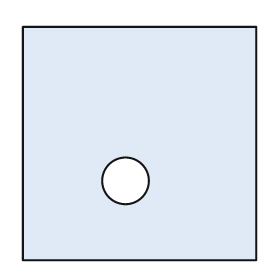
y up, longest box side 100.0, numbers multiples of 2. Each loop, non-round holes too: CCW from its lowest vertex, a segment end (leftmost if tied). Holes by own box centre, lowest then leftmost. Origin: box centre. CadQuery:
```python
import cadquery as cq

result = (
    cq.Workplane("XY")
    .moveTo(-50.0, -50.0)
    .lineTo(50.0, -50.0)
    .lineTo(50.0, 50.0)
    .lineTo(-50.0, 50.0)
    .close()
    .moveTo(-6.0, -16.0)
    .circle(10.0)
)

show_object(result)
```